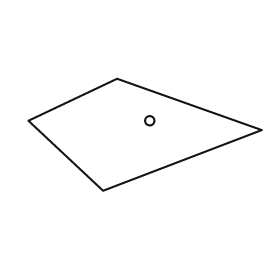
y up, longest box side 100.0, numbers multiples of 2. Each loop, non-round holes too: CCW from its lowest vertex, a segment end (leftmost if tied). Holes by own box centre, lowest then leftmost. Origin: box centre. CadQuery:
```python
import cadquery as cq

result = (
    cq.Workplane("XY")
    .moveTo(-18.0, -24.0)
    .lineTo(50.0, 2.0)
    .lineTo(-12.0, 24.0)
    .lineTo(-50.0, 6.0)
    .close()
    .moveTo(2.0, 6.0)
    .circle(2.0)
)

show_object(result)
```